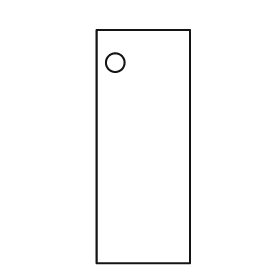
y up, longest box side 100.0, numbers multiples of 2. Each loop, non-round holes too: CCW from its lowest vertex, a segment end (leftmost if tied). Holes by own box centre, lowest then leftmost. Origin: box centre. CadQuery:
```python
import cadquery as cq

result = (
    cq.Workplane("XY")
    .moveTo(-20.0, -50.0)
    .lineTo(20.0, -50.0)
    .lineTo(20.0, 50.0)
    .lineTo(-20.0, 50.0)
    .close()
    .moveTo(-12.0, 36.0)
    .circle(4.0)
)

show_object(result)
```